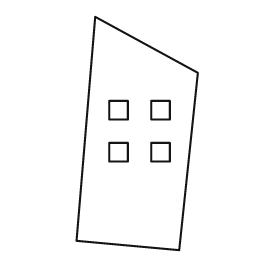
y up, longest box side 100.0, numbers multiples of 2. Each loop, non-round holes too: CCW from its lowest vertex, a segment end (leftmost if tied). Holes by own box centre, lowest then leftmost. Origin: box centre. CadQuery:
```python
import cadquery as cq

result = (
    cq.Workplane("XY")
    .moveTo(18.0, -50.0)
    .lineTo(26.0, 26.0)
    .lineTo(-18.0, 50.0)
    .lineTo(-26.0, -46.0)
    .close()
    .moveTo(-12.0, -12.0)
    .lineTo(-4.0, -12.0)
    .lineTo(-4.0, -4.0)
    .lineTo(-12.0, -4.0)
    .close()
    .moveTo(6.0, -12.0)
    .lineTo(14.0, -12.0)
    .lineTo(14.0, -4.0)
    .lineTo(6.0, -4.0)
    .close()
    .moveTo(-12.0, 6.0)
    .lineTo(-4.0, 6.0)
    .lineTo(-4.0, 14.0)
    .lineTo(-12.0, 14.0)
    .close()
    .moveTo(6.0, 6.0)
    .lineTo(14.0, 6.0)
    .lineTo(14.0, 14.0)
    .lineTo(6.0, 14.0)
    .close()
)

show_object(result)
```